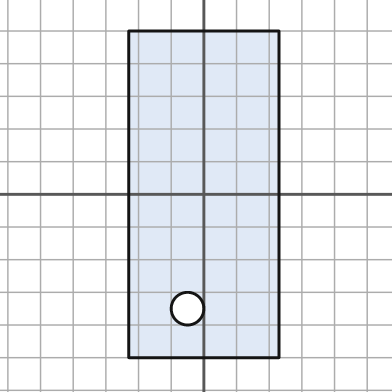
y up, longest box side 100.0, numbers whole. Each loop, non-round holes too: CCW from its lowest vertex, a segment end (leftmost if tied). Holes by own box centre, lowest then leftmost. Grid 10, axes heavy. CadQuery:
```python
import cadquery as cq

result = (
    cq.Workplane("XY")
    .moveTo(-23.0, -50.0)
    .lineTo(23.0, -50.0)
    .lineTo(23.0, 50.0)
    .lineTo(-23.0, 50.0)
    .close()
    .moveTo(-5.0, -35.0)
    .circle(5.0)
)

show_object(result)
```